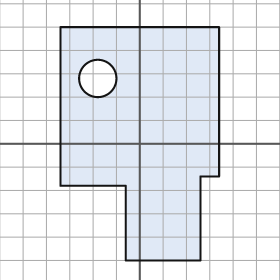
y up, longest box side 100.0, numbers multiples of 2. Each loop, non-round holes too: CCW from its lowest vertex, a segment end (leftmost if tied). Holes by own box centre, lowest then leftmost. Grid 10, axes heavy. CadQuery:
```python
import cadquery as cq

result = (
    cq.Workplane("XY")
    .moveTo(-6.0, -50.0)
    .lineTo(26.0, -50.0)
    .lineTo(26.0, -14.0)
    .lineTo(34.0, -14.0)
    .lineTo(34.0, 50.0)
    .lineTo(-34.0, 50.0)
    .lineTo(-34.0, -18.0)
    .lineTo(-6.0, -18.0)
    .close()
    .moveTo(-18.0, 28.0)
    .circle(8.0)
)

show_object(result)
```